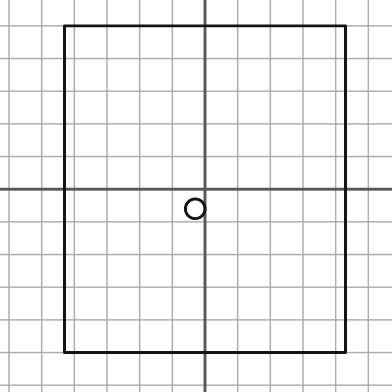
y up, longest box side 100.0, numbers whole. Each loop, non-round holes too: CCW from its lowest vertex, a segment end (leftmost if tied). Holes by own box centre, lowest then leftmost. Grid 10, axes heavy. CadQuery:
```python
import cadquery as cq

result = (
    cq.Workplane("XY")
    .moveTo(-43.0, -50.0)
    .lineTo(43.0, -50.0)
    .lineTo(43.0, 50.0)
    .lineTo(-43.0, 50.0)
    .close()
    .moveTo(-3.0, -6.0)
    .circle(3.0)
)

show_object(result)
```